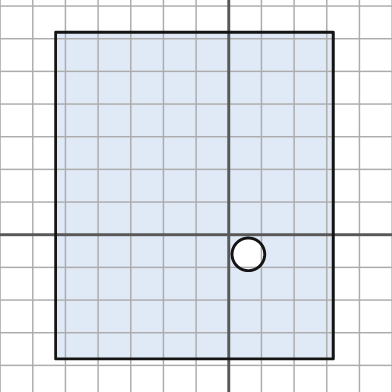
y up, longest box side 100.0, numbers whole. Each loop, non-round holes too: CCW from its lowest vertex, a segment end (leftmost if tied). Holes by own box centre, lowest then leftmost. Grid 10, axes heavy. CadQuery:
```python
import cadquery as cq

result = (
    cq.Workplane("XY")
    .moveTo(-53.0, -38.0)
    .lineTo(32.0, -38.0)
    .lineTo(32.0, 62.0)
    .lineTo(-53.0, 62.0)
    .close()
    .moveTo(6.0, -6.0)
    .circle(5.0)
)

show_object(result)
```